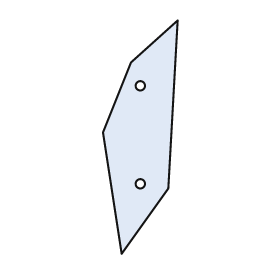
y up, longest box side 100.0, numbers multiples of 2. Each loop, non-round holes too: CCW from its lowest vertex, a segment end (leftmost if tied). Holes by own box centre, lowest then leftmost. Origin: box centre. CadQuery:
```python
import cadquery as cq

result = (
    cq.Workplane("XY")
    .moveTo(-8.0, -50.0)
    .lineTo(12.0, -22.0)
    .lineTo(16.0, 50.0)
    .lineTo(-4.0, 32.0)
    .lineTo(-16.0, 2.0)
    .close()
    .moveTo(0.0, -20.0)
    .circle(2.0)
    .moveTo(0.0, 22.0)
    .circle(2.0)
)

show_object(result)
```